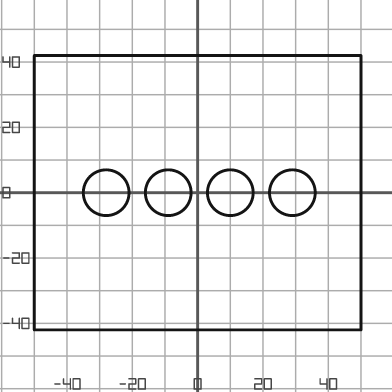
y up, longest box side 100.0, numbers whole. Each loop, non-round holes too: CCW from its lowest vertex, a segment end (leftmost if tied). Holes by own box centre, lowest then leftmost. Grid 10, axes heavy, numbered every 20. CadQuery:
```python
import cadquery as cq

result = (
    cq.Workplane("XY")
    .moveTo(-50.0, -42.0)
    .lineTo(50.0, -42.0)
    .lineTo(50.0, 42.0)
    .lineTo(-50.0, 42.0)
    .close()
    .moveTo(-28.0, 0.0)
    .circle(7.0)
    .moveTo(-9.0, 0.0)
    .circle(7.0)
    .moveTo(10.0, 0.0)
    .circle(7.0)
    .moveTo(29.0, 0.0)
    .circle(7.0)
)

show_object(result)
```